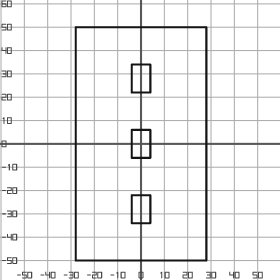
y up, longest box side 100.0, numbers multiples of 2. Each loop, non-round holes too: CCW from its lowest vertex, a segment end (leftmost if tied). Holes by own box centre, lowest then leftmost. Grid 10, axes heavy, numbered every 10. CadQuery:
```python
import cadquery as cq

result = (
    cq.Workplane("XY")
    .moveTo(-28.0, -50.0)
    .lineTo(28.0, -50.0)
    .lineTo(28.0, 50.0)
    .lineTo(-28.0, 50.0)
    .close()
    .moveTo(-4.0, -34.0)
    .lineTo(4.0, -34.0)
    .lineTo(4.0, -22.0)
    .lineTo(-4.0, -22.0)
    .close()
    .moveTo(-4.0, -6.0)
    .lineTo(4.0, -6.0)
    .lineTo(4.0, 6.0)
    .lineTo(-4.0, 6.0)
    .close()
    .moveTo(-4.0, 22.0)
    .lineTo(4.0, 22.0)
    .lineTo(4.0, 34.0)
    .lineTo(-4.0, 34.0)
    .close()
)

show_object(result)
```